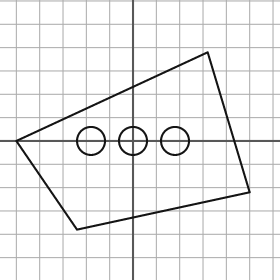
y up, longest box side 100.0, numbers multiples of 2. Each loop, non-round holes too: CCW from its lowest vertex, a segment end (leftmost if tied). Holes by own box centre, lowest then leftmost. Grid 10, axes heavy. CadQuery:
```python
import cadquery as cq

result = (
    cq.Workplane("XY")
    .moveTo(-24.0, -38.0)
    .lineTo(50.0, -22.0)
    .lineTo(32.0, 38.0)
    .lineTo(-50.0, 0.0)
    .close()
    .moveTo(-18.0, 0.0)
    .circle(6.0)
    .moveTo(0.0, 0.0)
    .circle(6.0)
    .moveTo(18.0, 0.0)
    .circle(6.0)
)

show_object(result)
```